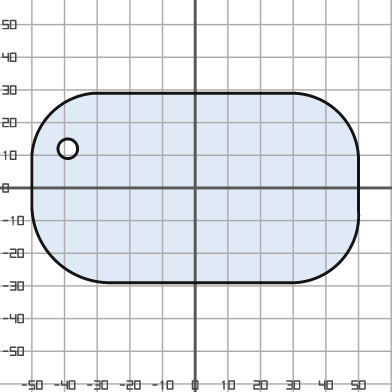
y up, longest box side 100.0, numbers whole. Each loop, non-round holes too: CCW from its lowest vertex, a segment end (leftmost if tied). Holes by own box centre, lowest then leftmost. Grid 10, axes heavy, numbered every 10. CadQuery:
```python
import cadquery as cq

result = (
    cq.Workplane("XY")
    .moveTo(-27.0, -29.0)
    .lineTo(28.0, -29.0)
    .threePointArc((44.0, -23.0), (50.0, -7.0))
    .lineTo(50.0, 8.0)
    .threePointArc((44.0, 23.0), (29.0, 29.0))
    .lineTo(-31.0, 29.0)
    .threePointArc((-44.0, 23.0), (-50.0, 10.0))
    .lineTo(-50.0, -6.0)
    .threePointArc((-43.0, -22.0), (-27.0, -29.0))
    .close()
    .moveTo(-39.0, 12.0)
    .circle(3.0)
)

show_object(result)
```